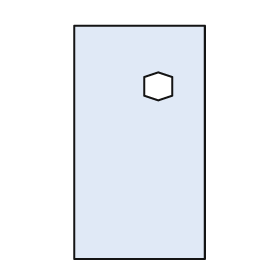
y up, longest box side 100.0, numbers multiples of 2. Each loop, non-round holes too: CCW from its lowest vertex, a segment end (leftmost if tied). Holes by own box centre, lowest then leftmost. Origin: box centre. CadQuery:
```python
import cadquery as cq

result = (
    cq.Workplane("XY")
    .moveTo(-28.0, -50.0)
    .lineTo(28.0, -50.0)
    .lineTo(28.0, 50.0)
    .lineTo(-28.0, 50.0)
    .close()
    .moveTo(8.0, 18.0)
    .lineTo(14.0, 20.0)
    .lineTo(14.0, 28.0)
    .lineTo(8.0, 30.0)
    .lineTo(2.0, 28.0)
    .lineTo(2.0, 20.0)
    .close()
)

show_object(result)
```